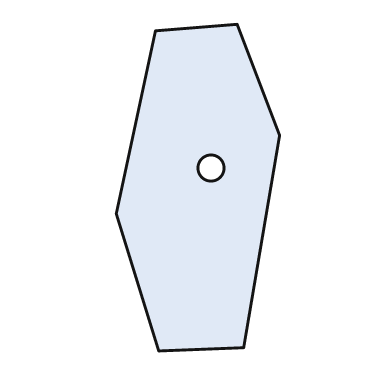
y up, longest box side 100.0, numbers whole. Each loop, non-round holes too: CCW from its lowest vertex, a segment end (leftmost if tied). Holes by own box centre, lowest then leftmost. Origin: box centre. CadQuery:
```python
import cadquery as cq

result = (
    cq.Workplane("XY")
    .moveTo(-12.0, -50.0)
    .lineTo(14.0, -49.0)
    .lineTo(25.0, 16.0)
    .lineTo(12.0, 50.0)
    .lineTo(-13.0, 48.0)
    .lineTo(-25.0, -8.0)
    .close()
    .moveTo(4.0, 6.0)
    .circle(4.0)
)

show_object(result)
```